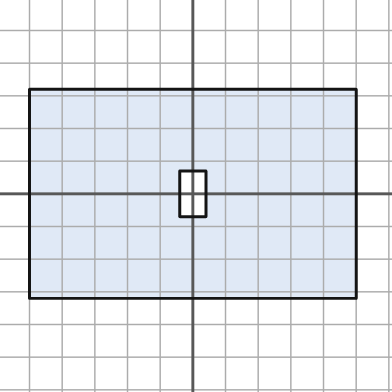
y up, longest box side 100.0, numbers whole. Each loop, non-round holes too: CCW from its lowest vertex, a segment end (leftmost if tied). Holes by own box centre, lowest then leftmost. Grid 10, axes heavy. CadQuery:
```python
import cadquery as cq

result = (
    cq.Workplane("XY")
    .moveTo(-50.0, -32.0)
    .lineTo(50.0, -32.0)
    .lineTo(50.0, 32.0)
    .lineTo(-50.0, 32.0)
    .close()
    .moveTo(-4.0, -7.0)
    .lineTo(4.0, -7.0)
    .lineTo(4.0, 7.0)
    .lineTo(-4.0, 7.0)
    .close()
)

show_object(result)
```